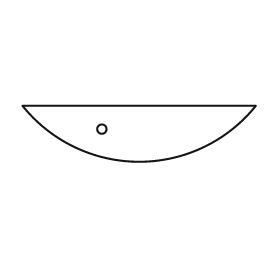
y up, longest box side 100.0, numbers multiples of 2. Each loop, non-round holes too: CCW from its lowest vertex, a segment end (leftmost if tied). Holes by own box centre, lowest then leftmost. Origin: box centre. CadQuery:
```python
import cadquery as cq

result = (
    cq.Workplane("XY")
    .moveTo(-50.0, 12.0)
    .threePointArc((0.0, -12.0), (50.0, 12.0))
    .close()
    .moveTo(-16.0, 2.0)
    .circle(2.0)
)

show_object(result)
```